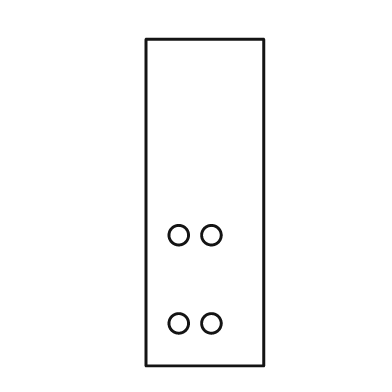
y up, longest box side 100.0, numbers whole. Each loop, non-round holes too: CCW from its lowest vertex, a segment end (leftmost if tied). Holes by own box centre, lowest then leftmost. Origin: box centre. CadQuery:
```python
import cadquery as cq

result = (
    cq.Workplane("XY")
    .moveTo(-18.0, -50.0)
    .lineTo(18.0, -50.0)
    .lineTo(18.0, 50.0)
    .lineTo(-18.0, 50.0)
    .close()
    .moveTo(-8.0, -37.0)
    .circle(3.0)
    .moveTo(2.0, -37.0)
    .circle(3.0)
    .moveTo(-8.0, -10.0)
    .circle(3.0)
    .moveTo(2.0, -10.0)
    .circle(3.0)
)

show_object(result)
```